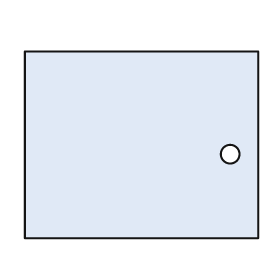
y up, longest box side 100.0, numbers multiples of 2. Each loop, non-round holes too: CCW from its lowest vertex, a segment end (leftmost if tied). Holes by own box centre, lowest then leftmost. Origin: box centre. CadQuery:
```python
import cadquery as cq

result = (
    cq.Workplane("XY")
    .moveTo(-50.0, -40.0)
    .lineTo(50.0, -40.0)
    .lineTo(50.0, 40.0)
    .lineTo(-50.0, 40.0)
    .close()
    .moveTo(38.0, -4.0)
    .circle(4.0)
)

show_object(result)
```